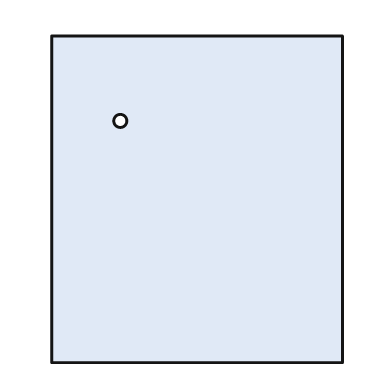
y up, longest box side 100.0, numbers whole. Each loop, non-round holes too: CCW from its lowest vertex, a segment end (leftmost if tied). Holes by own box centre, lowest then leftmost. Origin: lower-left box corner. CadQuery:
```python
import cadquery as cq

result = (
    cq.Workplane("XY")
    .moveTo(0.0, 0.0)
    .lineTo(89.0, 0.0)
    .lineTo(89.0, 100.0)
    .lineTo(0.0, 100.0)
    .close()
    .moveTo(21.0, 74.0)
    .circle(2.0)
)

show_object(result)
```